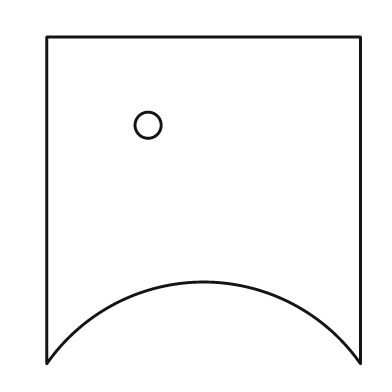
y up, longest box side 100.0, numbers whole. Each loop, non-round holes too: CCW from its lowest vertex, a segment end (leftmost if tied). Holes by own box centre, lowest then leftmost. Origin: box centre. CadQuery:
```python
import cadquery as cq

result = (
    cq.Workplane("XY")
    .moveTo(-48.0, -50.0)
    .threePointArc((0.0, -25.0), (48.0, -50.0))
    .lineTo(48.0, 50.0)
    .lineTo(-48.0, 50.0)
    .close()
    .moveTo(-17.0, 23.0)
    .circle(4.0)
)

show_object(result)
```